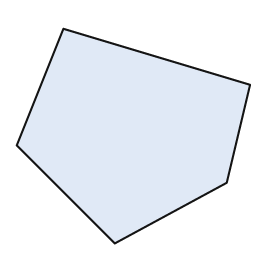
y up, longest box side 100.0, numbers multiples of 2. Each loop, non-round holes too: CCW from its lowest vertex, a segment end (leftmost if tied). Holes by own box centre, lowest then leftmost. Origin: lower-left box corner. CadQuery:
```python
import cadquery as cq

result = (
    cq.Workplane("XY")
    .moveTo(42.0, 0.0)
    .lineTo(90.0, 26.0)
    .lineTo(100.0, 68.0)
    .lineTo(20.0, 92.0)
    .lineTo(0.0, 42.0)
    .close()
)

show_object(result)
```